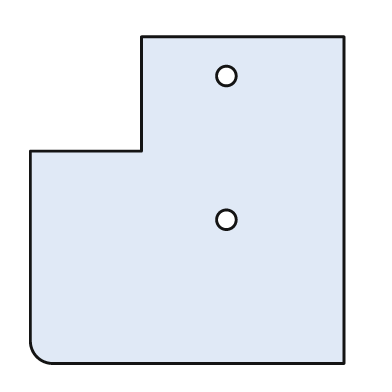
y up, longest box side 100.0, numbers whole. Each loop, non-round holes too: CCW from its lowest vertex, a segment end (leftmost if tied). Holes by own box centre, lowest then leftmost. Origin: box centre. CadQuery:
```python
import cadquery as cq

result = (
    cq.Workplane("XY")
    .moveTo(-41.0, -50.0)
    .lineTo(48.0, -50.0)
    .lineTo(48.0, 50.0)
    .lineTo(-14.0, 50.0)
    .lineTo(-14.0, 15.0)
    .lineTo(-48.0, 15.0)
    .lineTo(-48.0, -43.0)
    .threePointArc((-46.0, -48.0), (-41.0, -50.0))
    .close()
    .moveTo(12.0, -6.0)
    .circle(3.0)
    .moveTo(12.0, 38.0)
    .circle(3.0)
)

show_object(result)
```